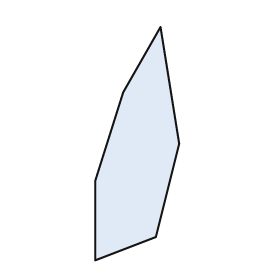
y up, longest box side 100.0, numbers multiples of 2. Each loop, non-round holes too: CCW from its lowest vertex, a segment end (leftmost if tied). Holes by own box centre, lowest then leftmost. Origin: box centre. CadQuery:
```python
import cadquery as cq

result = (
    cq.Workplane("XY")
    .moveTo(-18.0, -50.0)
    .lineTo(8.0, -40.0)
    .lineTo(18.0, 0.0)
    .lineTo(10.0, 50.0)
    .lineTo(-6.0, 22.0)
    .lineTo(-18.0, -16.0)
    .close()
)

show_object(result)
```